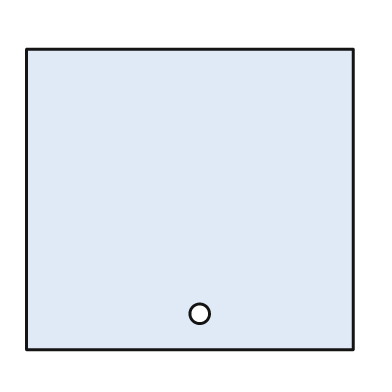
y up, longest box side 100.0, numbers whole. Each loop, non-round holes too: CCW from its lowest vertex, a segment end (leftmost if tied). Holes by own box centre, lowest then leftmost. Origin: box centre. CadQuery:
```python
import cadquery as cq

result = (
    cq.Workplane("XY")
    .moveTo(-50.0, -46.0)
    .lineTo(50.0, -46.0)
    .lineTo(50.0, 46.0)
    .lineTo(-50.0, 46.0)
    .close()
    .moveTo(3.0, -35.0)
    .circle(3.0)
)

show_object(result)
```